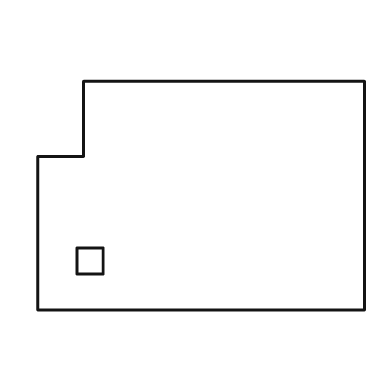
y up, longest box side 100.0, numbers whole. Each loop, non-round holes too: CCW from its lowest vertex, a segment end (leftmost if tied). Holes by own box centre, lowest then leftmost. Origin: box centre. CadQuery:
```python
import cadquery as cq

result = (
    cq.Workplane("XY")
    .moveTo(-50.0, -35.0)
    .lineTo(50.0, -35.0)
    .lineTo(50.0, 35.0)
    .lineTo(-36.0, 35.0)
    .lineTo(-36.0, 12.0)
    .lineTo(-50.0, 12.0)
    .close()
    .moveTo(-38.0, -24.0)
    .lineTo(-30.0, -24.0)
    .lineTo(-30.0, -16.0)
    .lineTo(-38.0, -16.0)
    .close()
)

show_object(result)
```